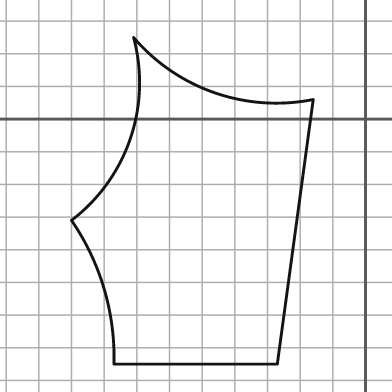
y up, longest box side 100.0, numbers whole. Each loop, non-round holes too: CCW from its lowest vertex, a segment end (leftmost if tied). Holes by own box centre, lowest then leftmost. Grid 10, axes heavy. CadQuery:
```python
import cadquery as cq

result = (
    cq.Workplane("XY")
    .moveTo(-77.0, -75.0)
    .lineTo(-27.0, -75.0)
    .lineTo(-16.0, 6.0)
    .threePointArc((-46.0, 8.0), (-71.0, 25.0))
    .threePointArc((-72.0, -6.0), (-90.0, -31.0))
    .threePointArc((-80.0, -52.0), (-77.0, -75.0))
    .close()
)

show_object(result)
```